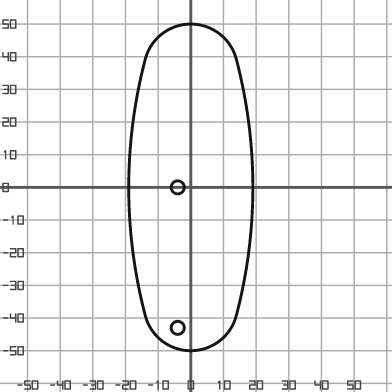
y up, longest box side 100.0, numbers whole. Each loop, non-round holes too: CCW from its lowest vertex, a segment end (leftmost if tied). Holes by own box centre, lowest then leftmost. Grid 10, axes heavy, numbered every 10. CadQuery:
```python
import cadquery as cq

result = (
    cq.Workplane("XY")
    .moveTo(-14.0, -39.0)
    .threePointArc((0.0, -50.0), (14.0, -39.0))
    .threePointArc((19.0, 0.0), (14.0, 39.0))
    .threePointArc((0.0, 50.0), (-14.0, 39.0))
    .threePointArc((-19.0, 0.0), (-14.0, -39.0))
    .close()
    .moveTo(-4.0, -43.0)
    .circle(2.0)
    .moveTo(-4.0, 0.0)
    .circle(2.0)
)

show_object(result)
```